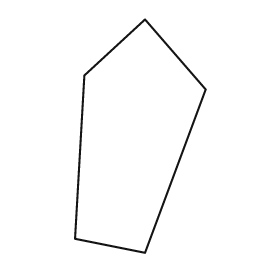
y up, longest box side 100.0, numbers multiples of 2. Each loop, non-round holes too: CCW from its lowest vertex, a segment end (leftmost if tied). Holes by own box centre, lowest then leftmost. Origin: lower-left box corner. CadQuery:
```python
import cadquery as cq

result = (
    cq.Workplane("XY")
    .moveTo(30.0, 0.0)
    .lineTo(56.0, 70.0)
    .lineTo(30.0, 100.0)
    .lineTo(4.0, 76.0)
    .lineTo(0.0, 6.0)
    .close()
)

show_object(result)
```